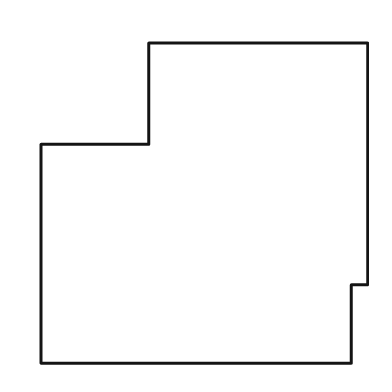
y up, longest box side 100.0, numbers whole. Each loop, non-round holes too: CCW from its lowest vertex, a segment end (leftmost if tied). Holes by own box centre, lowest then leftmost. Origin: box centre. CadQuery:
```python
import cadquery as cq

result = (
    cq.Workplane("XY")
    .moveTo(-50.0, -49.0)
    .lineTo(45.0, -49.0)
    .lineTo(45.0, -25.0)
    .lineTo(50.0, -25.0)
    .lineTo(50.0, 49.0)
    .lineTo(-17.0, 49.0)
    .lineTo(-17.0, 18.0)
    .lineTo(-50.0, 18.0)
    .close()
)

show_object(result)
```